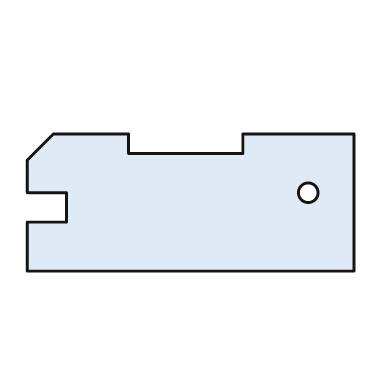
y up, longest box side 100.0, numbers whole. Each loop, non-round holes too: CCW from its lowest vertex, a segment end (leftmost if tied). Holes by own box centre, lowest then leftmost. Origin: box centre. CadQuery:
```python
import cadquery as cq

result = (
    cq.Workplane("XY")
    .moveTo(-50.0, -21.0)
    .lineTo(50.0, -21.0)
    .lineTo(50.0, 21.0)
    .lineTo(16.0, 21.0)
    .lineTo(16.0, 15.0)
    .lineTo(-19.0, 15.0)
    .lineTo(-19.0, 21.0)
    .lineTo(-42.0, 21.0)
    .lineTo(-50.0, 13.0)
    .lineTo(-50.0, 3.0)
    .lineTo(-38.0, 3.0)
    .lineTo(-38.0, -6.0)
    .lineTo(-50.0, -6.0)
    .close()
    .moveTo(36.0, 3.0)
    .circle(3.0)
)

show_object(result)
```